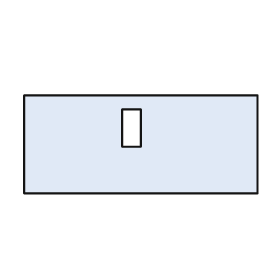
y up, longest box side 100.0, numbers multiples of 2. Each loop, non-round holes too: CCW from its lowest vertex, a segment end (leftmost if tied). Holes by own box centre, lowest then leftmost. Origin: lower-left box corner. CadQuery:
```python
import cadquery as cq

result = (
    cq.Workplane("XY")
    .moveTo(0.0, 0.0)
    .lineTo(100.0, 0.0)
    .lineTo(100.0, 42.0)
    .lineTo(0.0, 42.0)
    .close()
    .moveTo(42.0, 20.0)
    .lineTo(50.0, 20.0)
    .lineTo(50.0, 36.0)
    .lineTo(42.0, 36.0)
    .close()
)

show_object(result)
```